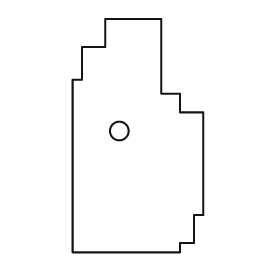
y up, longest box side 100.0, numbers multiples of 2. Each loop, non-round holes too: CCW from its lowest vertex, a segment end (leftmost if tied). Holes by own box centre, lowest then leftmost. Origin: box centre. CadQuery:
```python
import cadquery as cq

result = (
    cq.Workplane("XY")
    .moveTo(-28.0, -50.0)
    .lineTo(18.0, -50.0)
    .lineTo(18.0, -46.0)
    .lineTo(24.0, -46.0)
    .lineTo(24.0, -34.0)
    .lineTo(28.0, -34.0)
    .lineTo(28.0, 10.0)
    .lineTo(18.0, 10.0)
    .lineTo(18.0, 18.0)
    .lineTo(10.0, 18.0)
    .lineTo(10.0, 50.0)
    .lineTo(-14.0, 50.0)
    .lineTo(-14.0, 38.0)
    .lineTo(-24.0, 38.0)
    .lineTo(-24.0, 24.0)
    .lineTo(-28.0, 24.0)
    .close()
    .moveTo(-8.0, 2.0)
    .circle(4.0)
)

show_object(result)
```